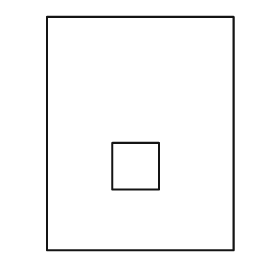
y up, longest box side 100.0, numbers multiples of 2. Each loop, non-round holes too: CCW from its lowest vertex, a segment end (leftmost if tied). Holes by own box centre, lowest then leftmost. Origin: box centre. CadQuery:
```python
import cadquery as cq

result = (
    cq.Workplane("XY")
    .moveTo(-40.0, -50.0)
    .lineTo(40.0, -50.0)
    .lineTo(40.0, 50.0)
    .lineTo(-40.0, 50.0)
    .close()
    .moveTo(-12.0, -24.0)
    .lineTo(8.0, -24.0)
    .lineTo(8.0, -4.0)
    .lineTo(-12.0, -4.0)
    .close()
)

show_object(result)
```